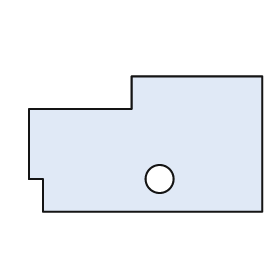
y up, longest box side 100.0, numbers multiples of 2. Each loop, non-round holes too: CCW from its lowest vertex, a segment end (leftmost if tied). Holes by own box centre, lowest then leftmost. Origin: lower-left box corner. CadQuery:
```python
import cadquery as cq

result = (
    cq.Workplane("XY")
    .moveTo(6.0, 0.0)
    .lineTo(100.0, 0.0)
    .lineTo(100.0, 58.0)
    .lineTo(44.0, 58.0)
    .lineTo(44.0, 44.0)
    .lineTo(0.0, 44.0)
    .lineTo(0.0, 14.0)
    .lineTo(6.0, 14.0)
    .close()
    .moveTo(56.0, 14.0)
    .circle(6.0)
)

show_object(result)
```